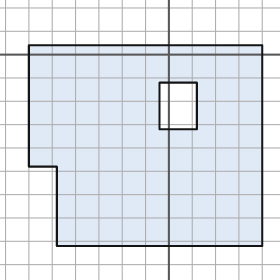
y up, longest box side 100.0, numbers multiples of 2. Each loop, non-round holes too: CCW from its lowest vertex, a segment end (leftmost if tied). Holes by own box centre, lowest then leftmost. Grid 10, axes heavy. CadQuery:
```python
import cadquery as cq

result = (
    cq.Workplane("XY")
    .moveTo(-48.0, -82.0)
    .lineTo(40.0, -82.0)
    .lineTo(40.0, 4.0)
    .lineTo(-60.0, 4.0)
    .lineTo(-60.0, -48.0)
    .lineTo(-48.0, -48.0)
    .close()
    .moveTo(-4.0, -32.0)
    .lineTo(12.0, -32.0)
    .lineTo(12.0, -12.0)
    .lineTo(-4.0, -12.0)
    .close()
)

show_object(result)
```